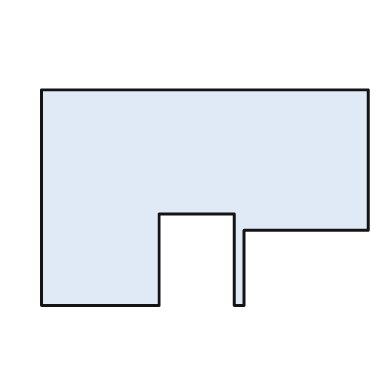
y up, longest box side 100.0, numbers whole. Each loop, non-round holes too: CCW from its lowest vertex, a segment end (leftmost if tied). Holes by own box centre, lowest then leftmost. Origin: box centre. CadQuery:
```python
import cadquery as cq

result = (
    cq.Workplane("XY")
    .moveTo(-50.0, -33.0)
    .lineTo(-14.0, -33.0)
    .lineTo(-14.0, -5.0)
    .lineTo(9.0, -5.0)
    .lineTo(9.0, -33.0)
    .lineTo(12.0, -33.0)
    .lineTo(12.0, -10.0)
    .lineTo(50.0, -10.0)
    .lineTo(50.0, 33.0)
    .lineTo(-50.0, 33.0)
    .close()
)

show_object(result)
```